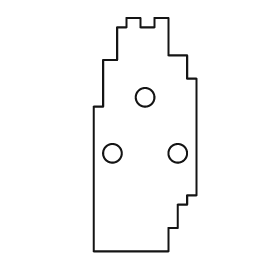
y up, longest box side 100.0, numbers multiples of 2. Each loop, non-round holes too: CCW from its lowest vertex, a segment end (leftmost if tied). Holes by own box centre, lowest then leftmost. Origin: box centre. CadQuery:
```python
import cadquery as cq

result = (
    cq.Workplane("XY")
    .moveTo(-22.0, -50.0)
    .lineTo(10.0, -50.0)
    .lineTo(10.0, -40.0)
    .lineTo(14.0, -40.0)
    .lineTo(14.0, -30.0)
    .lineTo(18.0, -30.0)
    .lineTo(18.0, -26.0)
    .lineTo(22.0, -26.0)
    .lineTo(22.0, 24.0)
    .lineTo(18.0, 24.0)
    .lineTo(18.0, 34.0)
    .lineTo(10.0, 34.0)
    .lineTo(10.0, 50.0)
    .lineTo(4.0, 50.0)
    .lineTo(4.0, 46.0)
    .lineTo(-2.0, 46.0)
    .lineTo(-2.0, 50.0)
    .lineTo(-8.0, 50.0)
    .lineTo(-8.0, 46.0)
    .lineTo(-12.0, 46.0)
    .lineTo(-12.0, 32.0)
    .lineTo(-18.0, 32.0)
    .lineTo(-18.0, 12.0)
    .lineTo(-22.0, 12.0)
    .close()
    .moveTo(-14.0, -8.0)
    .circle(4.0)
    .moveTo(14.0, -8.0)
    .circle(4.0)
    .moveTo(0.0, 16.0)
    .circle(4.0)
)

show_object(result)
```